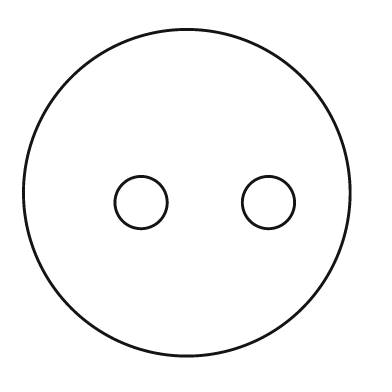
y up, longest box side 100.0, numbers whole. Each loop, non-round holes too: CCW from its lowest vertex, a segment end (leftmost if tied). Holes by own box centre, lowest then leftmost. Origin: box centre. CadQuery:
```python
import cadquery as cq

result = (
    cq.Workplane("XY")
    .moveTo(0.0, 0.0)
    .circle(50.0)
    .moveTo(-14.0, -3.0)
    .circle(8.0)
    .moveTo(25.0, -3.0)
    .circle(8.0)
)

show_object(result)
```